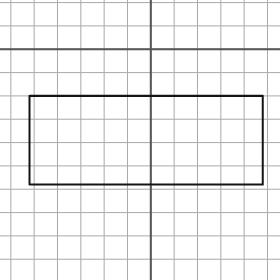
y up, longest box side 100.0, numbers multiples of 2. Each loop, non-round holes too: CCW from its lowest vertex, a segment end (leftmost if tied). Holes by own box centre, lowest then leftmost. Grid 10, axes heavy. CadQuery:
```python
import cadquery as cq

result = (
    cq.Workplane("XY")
    .moveTo(-52.0, -58.0)
    .lineTo(48.0, -58.0)
    .lineTo(48.0, -20.0)
    .lineTo(-52.0, -20.0)
    .close()
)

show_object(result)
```